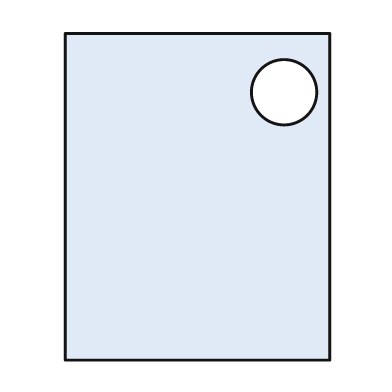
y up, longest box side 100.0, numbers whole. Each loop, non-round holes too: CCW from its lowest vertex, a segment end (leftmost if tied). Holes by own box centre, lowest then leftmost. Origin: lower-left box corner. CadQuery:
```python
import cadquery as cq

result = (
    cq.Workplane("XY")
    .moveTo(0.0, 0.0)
    .lineTo(81.0, 0.0)
    .lineTo(81.0, 100.0)
    .lineTo(0.0, 100.0)
    .close()
    .moveTo(67.0, 82.0)
    .circle(10.0)
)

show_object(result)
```